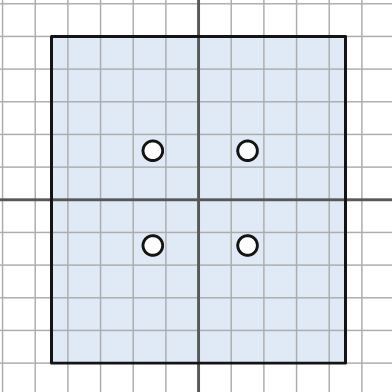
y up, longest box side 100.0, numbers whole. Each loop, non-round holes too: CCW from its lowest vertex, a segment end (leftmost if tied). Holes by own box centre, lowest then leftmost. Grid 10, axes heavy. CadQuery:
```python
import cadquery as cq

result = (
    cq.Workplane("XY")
    .moveTo(-45.0, -50.0)
    .lineTo(45.0, -50.0)
    .lineTo(45.0, 50.0)
    .lineTo(-45.0, 50.0)
    .close()
    .moveTo(-14.0, -14.0)
    .circle(3.0)
    .moveTo(15.0, -14.0)
    .circle(3.0)
    .moveTo(-14.0, 15.0)
    .circle(3.0)
    .moveTo(15.0, 15.0)
    .circle(3.0)
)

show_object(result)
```